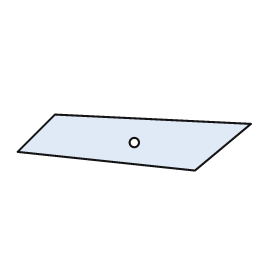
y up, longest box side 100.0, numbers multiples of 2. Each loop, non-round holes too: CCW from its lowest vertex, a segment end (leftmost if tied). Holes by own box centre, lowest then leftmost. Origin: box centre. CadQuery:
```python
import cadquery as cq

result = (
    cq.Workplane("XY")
    .moveTo(26.0, -12.0)
    .lineTo(50.0, 8.0)
    .lineTo(-34.0, 12.0)
    .lineTo(-50.0, -4.0)
    .close()
    .moveTo(0.0, 0.0)
    .circle(2.0)
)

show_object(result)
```